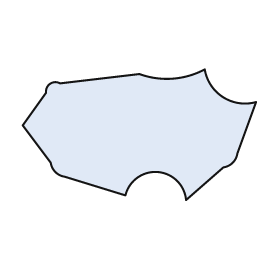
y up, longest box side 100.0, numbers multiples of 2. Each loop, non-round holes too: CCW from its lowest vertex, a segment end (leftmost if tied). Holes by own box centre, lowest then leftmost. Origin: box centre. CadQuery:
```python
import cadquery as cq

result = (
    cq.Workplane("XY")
    .moveTo(20.0, -28.0)
    .lineTo(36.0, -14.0)
    .threePointArc((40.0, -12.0), (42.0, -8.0))
    .lineTo(50.0, 14.0)
    .threePointArc((36.0, 16.0), (28.0, 28.0))
    .threePointArc((14.0, 24.0), (0.0, 26.0))
    .lineTo(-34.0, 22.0)
    .threePointArc((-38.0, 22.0), (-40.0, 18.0))
    .lineTo(-50.0, 4.0)
    .lineTo(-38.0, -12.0)
    .threePointArc((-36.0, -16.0), (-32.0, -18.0))
    .lineTo(-6.0, -26.0)
    .threePointArc((8.0, -16.0), (20.0, -28.0))
    .close()
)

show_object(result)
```